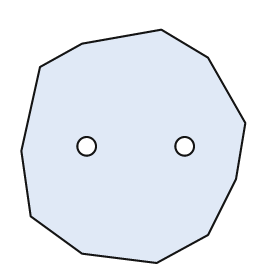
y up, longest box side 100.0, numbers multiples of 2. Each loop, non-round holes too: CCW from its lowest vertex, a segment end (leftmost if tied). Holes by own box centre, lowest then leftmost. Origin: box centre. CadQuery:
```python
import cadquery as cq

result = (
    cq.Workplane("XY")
    .moveTo(10.0, -50.0)
    .lineTo(32.0, -38.0)
    .lineTo(44.0, -14.0)
    .lineTo(48.0, 10.0)
    .lineTo(32.0, 38.0)
    .lineTo(12.0, 50.0)
    .lineTo(-22.0, 44.0)
    .lineTo(-40.0, 34.0)
    .lineTo(-48.0, -2.0)
    .lineTo(-44.0, -30.0)
    .lineTo(-22.0, -46.0)
    .close()
    .moveTo(-20.0, 0.0)
    .circle(4.0)
    .moveTo(22.0, 0.0)
    .circle(4.0)
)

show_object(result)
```